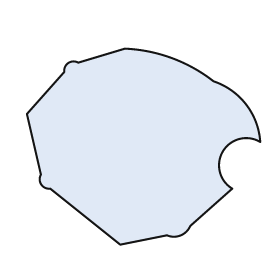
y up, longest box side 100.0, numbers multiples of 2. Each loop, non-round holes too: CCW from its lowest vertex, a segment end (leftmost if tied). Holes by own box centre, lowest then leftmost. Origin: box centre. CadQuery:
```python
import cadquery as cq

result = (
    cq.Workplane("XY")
    .moveTo(-10.0, -42.0)
    .lineTo(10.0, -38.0)
    .threePointArc((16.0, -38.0), (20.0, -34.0))
    .lineTo(38.0, -18.0)
    .threePointArc((34.0, -2.0), (50.0, 2.0))
    .threePointArc((44.0, 18.0), (30.0, 28.0))
    .threePointArc((12.0, 38.0), (-8.0, 42.0))
    .lineTo(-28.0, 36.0)
    .threePointArc((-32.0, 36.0), (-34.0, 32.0))
    .lineTo(-50.0, 14.0)
    .lineTo(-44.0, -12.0)
    .threePointArc((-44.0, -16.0), (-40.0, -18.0))
    .close()
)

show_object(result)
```